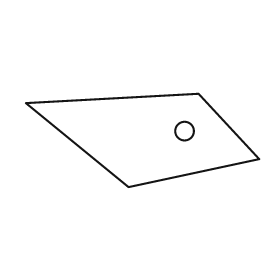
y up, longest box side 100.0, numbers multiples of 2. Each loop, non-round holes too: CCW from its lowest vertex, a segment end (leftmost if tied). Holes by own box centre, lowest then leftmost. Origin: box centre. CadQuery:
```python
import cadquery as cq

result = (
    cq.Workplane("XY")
    .moveTo(-6.0, -20.0)
    .lineTo(50.0, -8.0)
    .lineTo(24.0, 20.0)
    .lineTo(-50.0, 16.0)
    .close()
    .moveTo(18.0, 4.0)
    .circle(4.0)
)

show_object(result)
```